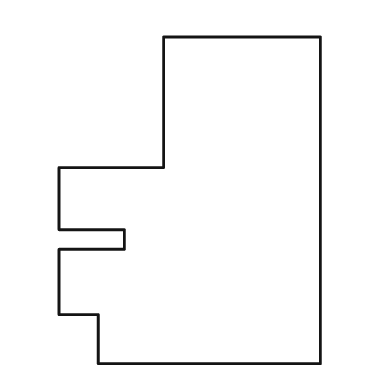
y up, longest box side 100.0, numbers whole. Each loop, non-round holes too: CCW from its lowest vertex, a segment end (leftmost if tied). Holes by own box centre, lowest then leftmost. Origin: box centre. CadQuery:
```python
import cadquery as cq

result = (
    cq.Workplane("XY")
    .moveTo(-28.0, -50.0)
    .lineTo(40.0, -50.0)
    .lineTo(40.0, 50.0)
    .lineTo(-8.0, 50.0)
    .lineTo(-8.0, 10.0)
    .lineTo(-40.0, 10.0)
    .lineTo(-40.0, -9.0)
    .lineTo(-20.0, -9.0)
    .lineTo(-20.0, -15.0)
    .lineTo(-40.0, -15.0)
    .lineTo(-40.0, -35.0)
    .lineTo(-28.0, -35.0)
    .close()
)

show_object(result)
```